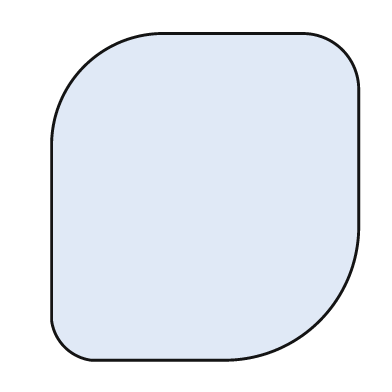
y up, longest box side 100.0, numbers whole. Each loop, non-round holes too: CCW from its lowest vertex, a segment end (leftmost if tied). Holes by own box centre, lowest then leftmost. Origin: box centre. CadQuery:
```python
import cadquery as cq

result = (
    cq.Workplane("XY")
    .moveTo(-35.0, -50.0)
    .lineTo(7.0, -50.0)
    .threePointArc((35.0, -38.0), (47.0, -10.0))
    .lineTo(47.0, 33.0)
    .threePointArc((42.0, 45.0), (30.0, 50.0))
    .lineTo(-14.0, 50.0)
    .threePointArc((-37.0, 40.0), (-47.0, 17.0))
    .lineTo(-47.0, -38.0)
    .threePointArc((-43.0, -46.0), (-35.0, -50.0))
    .close()
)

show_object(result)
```